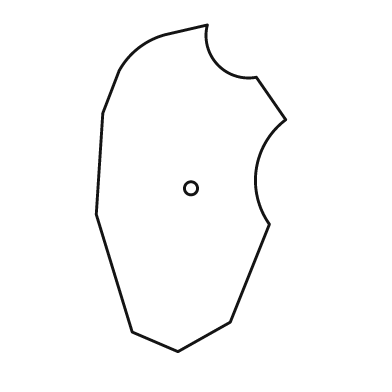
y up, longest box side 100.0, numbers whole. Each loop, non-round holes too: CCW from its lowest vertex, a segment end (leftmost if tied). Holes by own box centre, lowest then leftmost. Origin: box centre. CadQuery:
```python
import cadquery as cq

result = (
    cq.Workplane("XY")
    .moveTo(-4.0, -50.0)
    .lineTo(12.0, -41.0)
    .lineTo(24.0, -11.0)
    .threePointArc((20.0, 6.0), (29.0, 21.0))
    .lineTo(20.0, 34.0)
    .threePointArc((8.0, 38.0), (5.0, 50.0))
    .lineTo(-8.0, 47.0)
    .threePointArc((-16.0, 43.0), (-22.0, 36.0))
    .lineTo(-27.0, 23.0)
    .lineTo(-29.0, -8.0)
    .lineTo(-18.0, -44.0)
    .close()
    .moveTo(0.0, 0.0)
    .circle(2.0)
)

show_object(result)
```